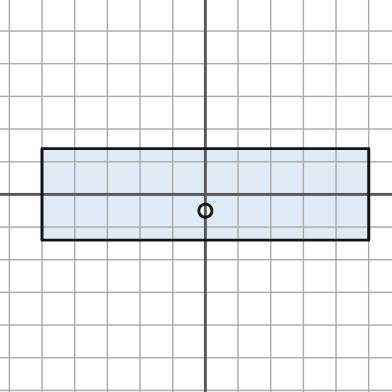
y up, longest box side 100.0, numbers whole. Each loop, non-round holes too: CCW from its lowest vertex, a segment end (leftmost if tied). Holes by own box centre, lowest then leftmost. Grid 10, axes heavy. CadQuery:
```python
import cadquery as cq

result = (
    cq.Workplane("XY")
    .moveTo(-50.0, -14.0)
    .lineTo(50.0, -14.0)
    .lineTo(50.0, 14.0)
    .lineTo(-50.0, 14.0)
    .close()
    .moveTo(0.0, -5.0)
    .circle(2.0)
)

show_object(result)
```